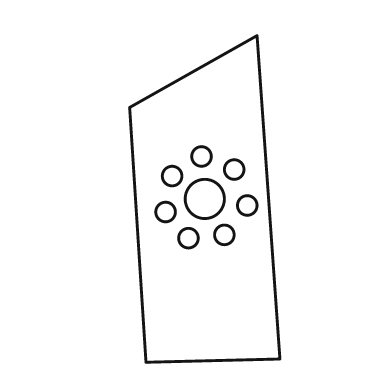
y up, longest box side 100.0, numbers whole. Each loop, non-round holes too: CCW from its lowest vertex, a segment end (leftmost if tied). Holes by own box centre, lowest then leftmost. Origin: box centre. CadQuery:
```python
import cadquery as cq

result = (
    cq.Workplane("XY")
    .moveTo(-18.0, -50.0)
    .lineTo(23.0, -49.0)
    .lineTo(16.0, 50.0)
    .lineTo(-23.0, 28.0)
    .close()
    .moveTo(-5.0, -12.0)
    .circle(3.0)
    .moveTo(6.0, -11.0)
    .circle(3.0)
    .moveTo(-12.0, -4.0)
    .circle(3.0)
    .moveTo(13.0, -2.0)
    .circle(3.0)
    .moveTo(0.0, 0.0)
    .circle(6.0)
    .moveTo(-10.0, 7.0)
    .circle(3.0)
    .moveTo(9.0, 9.0)
    .circle(3.0)
    .moveTo(-1.0, 13.0)
    .circle(3.0)
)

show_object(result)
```